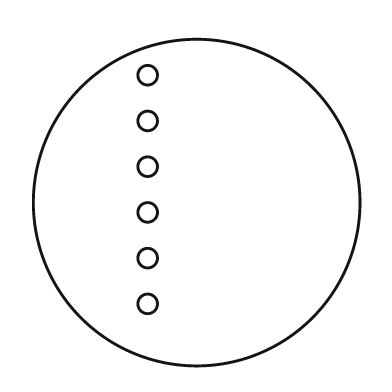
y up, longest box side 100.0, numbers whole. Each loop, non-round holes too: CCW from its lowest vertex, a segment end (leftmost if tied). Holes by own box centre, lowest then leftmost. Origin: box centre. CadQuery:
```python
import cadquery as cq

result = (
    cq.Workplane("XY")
    .moveTo(0.0, 0.0)
    .circle(50.0)
    .moveTo(-15.0, -31.0)
    .circle(3.0)
    .moveTo(-15.0, -17.0)
    .circle(3.0)
    .moveTo(-15.0, -3.0)
    .circle(3.0)
    .moveTo(-15.0, 11.0)
    .circle(3.0)
    .moveTo(-15.0, 25.0)
    .circle(3.0)
    .moveTo(-15.0, 39.0)
    .circle(3.0)
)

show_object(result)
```